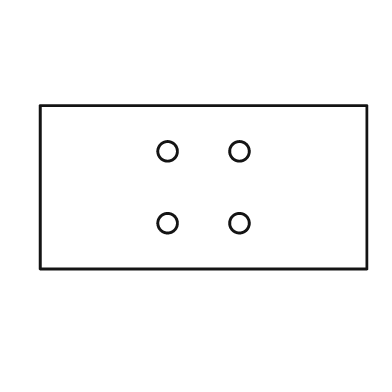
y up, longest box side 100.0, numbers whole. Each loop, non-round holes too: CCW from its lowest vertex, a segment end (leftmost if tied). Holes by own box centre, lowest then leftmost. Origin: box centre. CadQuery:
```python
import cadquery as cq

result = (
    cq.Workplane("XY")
    .moveTo(-50.0, -25.0)
    .lineTo(50.0, -25.0)
    .lineTo(50.0, 25.0)
    .lineTo(-50.0, 25.0)
    .close()
    .moveTo(-11.0, -11.0)
    .circle(3.0)
    .moveTo(11.0, -11.0)
    .circle(3.0)
    .moveTo(-11.0, 11.0)
    .circle(3.0)
    .moveTo(11.0, 11.0)
    .circle(3.0)
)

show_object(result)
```